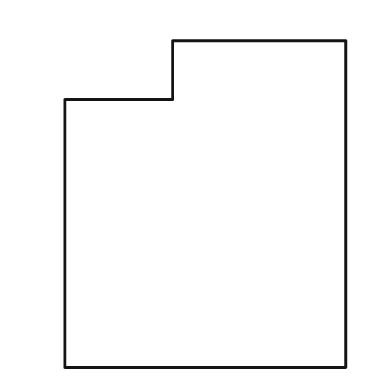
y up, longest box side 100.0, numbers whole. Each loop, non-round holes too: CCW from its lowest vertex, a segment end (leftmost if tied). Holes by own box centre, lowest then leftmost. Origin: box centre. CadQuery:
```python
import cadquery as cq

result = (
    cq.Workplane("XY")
    .moveTo(-43.0, -50.0)
    .lineTo(43.0, -50.0)
    .lineTo(43.0, 50.0)
    .lineTo(-10.0, 50.0)
    .lineTo(-10.0, 32.0)
    .lineTo(-43.0, 32.0)
    .close()
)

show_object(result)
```